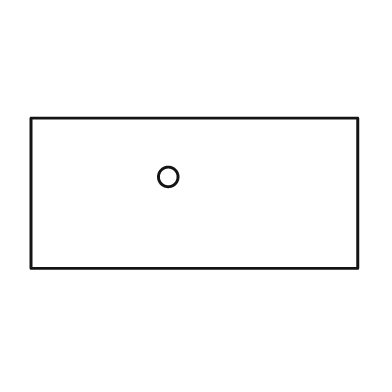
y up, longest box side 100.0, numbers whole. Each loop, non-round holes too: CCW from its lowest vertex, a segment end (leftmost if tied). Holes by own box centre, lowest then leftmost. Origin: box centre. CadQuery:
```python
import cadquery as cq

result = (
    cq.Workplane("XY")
    .moveTo(-50.0, -23.0)
    .lineTo(50.0, -23.0)
    .lineTo(50.0, 23.0)
    .lineTo(-50.0, 23.0)
    .close()
    .moveTo(-8.0, 5.0)
    .circle(3.0)
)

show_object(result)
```